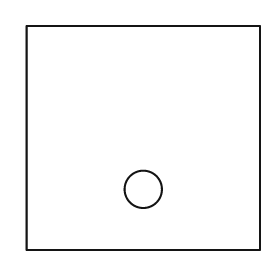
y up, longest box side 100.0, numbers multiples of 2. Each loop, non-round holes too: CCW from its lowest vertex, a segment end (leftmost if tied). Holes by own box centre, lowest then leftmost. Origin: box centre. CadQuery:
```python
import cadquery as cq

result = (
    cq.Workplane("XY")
    .moveTo(-50.0, -48.0)
    .lineTo(50.0, -48.0)
    .lineTo(50.0, 48.0)
    .lineTo(-50.0, 48.0)
    .close()
    .moveTo(0.0, -22.0)
    .circle(8.0)
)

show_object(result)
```